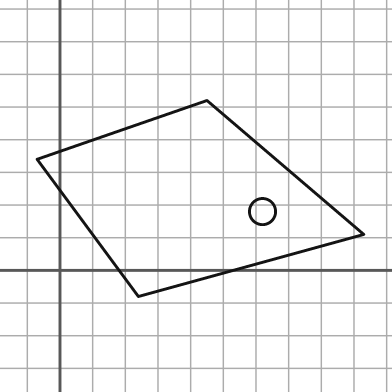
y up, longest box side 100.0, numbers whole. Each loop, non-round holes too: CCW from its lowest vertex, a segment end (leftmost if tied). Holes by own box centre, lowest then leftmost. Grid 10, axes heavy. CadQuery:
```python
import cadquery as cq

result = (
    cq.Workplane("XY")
    .moveTo(24.0, -8.0)
    .lineTo(93.0, 11.0)
    .lineTo(45.0, 52.0)
    .lineTo(-7.0, 34.0)
    .close()
    .moveTo(62.0, 18.0)
    .circle(4.0)
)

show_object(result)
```